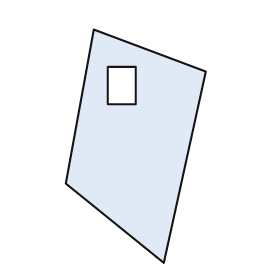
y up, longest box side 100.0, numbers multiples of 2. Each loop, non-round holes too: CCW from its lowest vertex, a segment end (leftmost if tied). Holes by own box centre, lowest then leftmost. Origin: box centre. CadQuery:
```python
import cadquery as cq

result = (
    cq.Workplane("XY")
    .moveTo(12.0, -50.0)
    .lineTo(30.0, 32.0)
    .lineTo(-18.0, 50.0)
    .lineTo(-30.0, -16.0)
    .close()
    .moveTo(-12.0, 18.0)
    .lineTo(0.0, 18.0)
    .lineTo(0.0, 34.0)
    .lineTo(-12.0, 34.0)
    .close()
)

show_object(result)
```